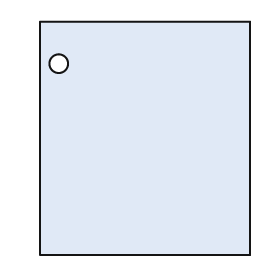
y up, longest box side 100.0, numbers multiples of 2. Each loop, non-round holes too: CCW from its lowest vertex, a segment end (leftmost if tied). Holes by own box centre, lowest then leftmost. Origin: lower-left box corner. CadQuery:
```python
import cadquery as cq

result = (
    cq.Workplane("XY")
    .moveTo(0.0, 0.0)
    .lineTo(90.0, 0.0)
    .lineTo(90.0, 100.0)
    .lineTo(0.0, 100.0)
    .close()
    .moveTo(8.0, 82.0)
    .circle(4.0)
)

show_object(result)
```